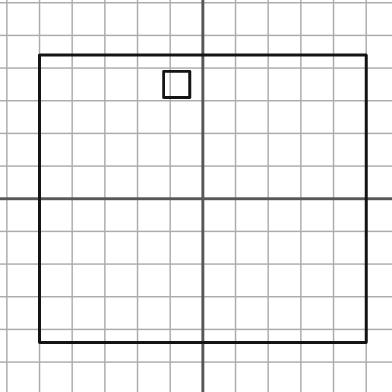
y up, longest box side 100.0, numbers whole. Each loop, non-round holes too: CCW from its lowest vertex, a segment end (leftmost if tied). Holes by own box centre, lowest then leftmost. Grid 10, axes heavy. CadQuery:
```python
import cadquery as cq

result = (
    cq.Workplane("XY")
    .moveTo(-50.0, -44.0)
    .lineTo(50.0, -44.0)
    .lineTo(50.0, 44.0)
    .lineTo(-50.0, 44.0)
    .close()
    .moveTo(-12.0, 31.0)
    .lineTo(-4.0, 31.0)
    .lineTo(-4.0, 39.0)
    .lineTo(-12.0, 39.0)
    .close()
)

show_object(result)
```